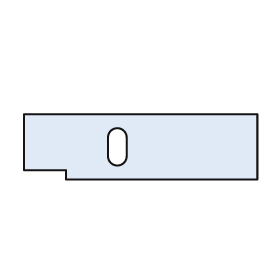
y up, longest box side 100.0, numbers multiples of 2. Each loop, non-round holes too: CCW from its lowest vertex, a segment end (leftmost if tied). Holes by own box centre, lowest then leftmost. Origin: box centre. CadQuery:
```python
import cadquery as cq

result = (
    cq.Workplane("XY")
    .moveTo(-32.0, -14.0)
    .lineTo(50.0, -14.0)
    .lineTo(50.0, 14.0)
    .lineTo(-50.0, 14.0)
    .lineTo(-50.0, -10.0)
    .lineTo(-32.0, -10.0)
    .close()
    .moveTo(-14.0, -4.0)
    .threePointArc((-10.0, -8.0), (-6.0, -4.0))
    .lineTo(-6.0, 4.0)
    .threePointArc((-10.0, 8.0), (-14.0, 4.0))
    .close()
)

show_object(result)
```